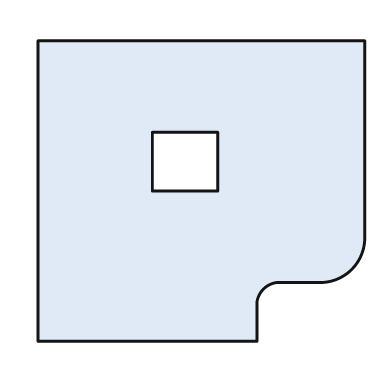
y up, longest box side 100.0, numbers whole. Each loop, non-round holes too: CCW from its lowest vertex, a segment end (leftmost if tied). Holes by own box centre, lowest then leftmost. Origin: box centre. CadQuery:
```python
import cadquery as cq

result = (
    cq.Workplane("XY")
    .moveTo(-50.0, -46.0)
    .lineTo(17.0, -46.0)
    .lineTo(17.0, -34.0)
    .threePointArc((19.0, -30.0), (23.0, -28.0))
    .lineTo(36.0, -28.0)
    .threePointArc((46.0, -24.0), (50.0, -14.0))
    .lineTo(50.0, 46.0)
    .lineTo(-50.0, 46.0)
    .close()
    .moveTo(-15.0, 0.0)
    .lineTo(5.0, 0.0)
    .lineTo(5.0, 18.0)
    .lineTo(-15.0, 18.0)
    .close()
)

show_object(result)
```